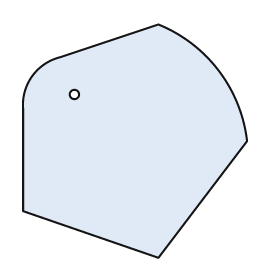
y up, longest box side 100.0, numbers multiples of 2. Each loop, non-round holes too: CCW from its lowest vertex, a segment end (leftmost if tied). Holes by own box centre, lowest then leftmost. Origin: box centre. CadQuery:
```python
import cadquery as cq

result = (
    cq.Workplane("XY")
    .moveTo(10.0, -50.0)
    .lineTo(48.0, 0.0)
    .threePointArc((36.0, 30.0), (10.0, 50.0))
    .lineTo(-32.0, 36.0)
    .threePointArc((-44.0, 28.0), (-48.0, 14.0))
    .lineTo(-48.0, -30.0)
    .close()
    .moveTo(-26.0, 20.0)
    .circle(2.0)
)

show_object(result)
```